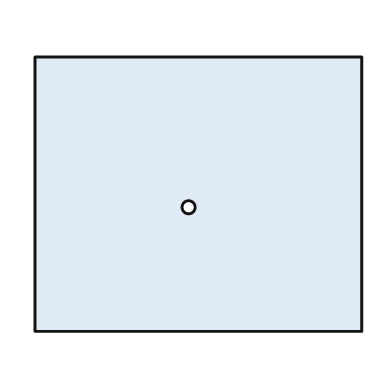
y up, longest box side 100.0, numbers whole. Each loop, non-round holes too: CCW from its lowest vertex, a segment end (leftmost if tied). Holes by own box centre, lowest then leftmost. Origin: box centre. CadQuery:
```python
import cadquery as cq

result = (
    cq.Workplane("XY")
    .moveTo(-50.0, -42.0)
    .lineTo(50.0, -42.0)
    .lineTo(50.0, 42.0)
    .lineTo(-50.0, 42.0)
    .close()
    .moveTo(-3.0, -4.0)
    .circle(2.0)
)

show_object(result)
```